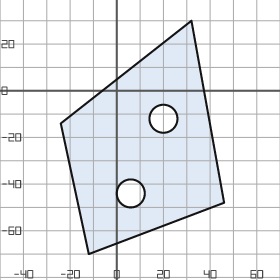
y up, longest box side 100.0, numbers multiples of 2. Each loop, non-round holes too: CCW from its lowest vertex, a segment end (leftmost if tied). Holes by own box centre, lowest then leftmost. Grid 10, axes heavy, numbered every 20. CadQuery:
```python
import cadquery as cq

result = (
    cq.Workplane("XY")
    .moveTo(-12.0, -70.0)
    .lineTo(46.0, -48.0)
    .lineTo(32.0, 30.0)
    .lineTo(-24.0, -14.0)
    .close()
    .moveTo(6.0, -44.0)
    .circle(6.0)
    .moveTo(20.0, -12.0)
    .circle(6.0)
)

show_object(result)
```